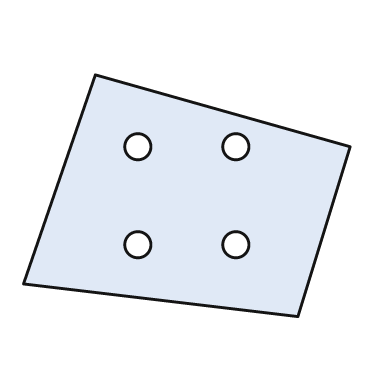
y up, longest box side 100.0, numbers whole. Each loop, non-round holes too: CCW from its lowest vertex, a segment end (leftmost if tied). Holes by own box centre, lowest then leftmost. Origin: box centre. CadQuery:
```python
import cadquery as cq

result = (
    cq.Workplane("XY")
    .moveTo(34.0, -37.0)
    .lineTo(50.0, 15.0)
    .lineTo(-28.0, 37.0)
    .lineTo(-50.0, -27.0)
    .close()
    .moveTo(-15.0, -15.0)
    .circle(4.0)
    .moveTo(15.0, -15.0)
    .circle(4.0)
    .moveTo(-15.0, 15.0)
    .circle(4.0)
    .moveTo(15.0, 15.0)
    .circle(4.0)
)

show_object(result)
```